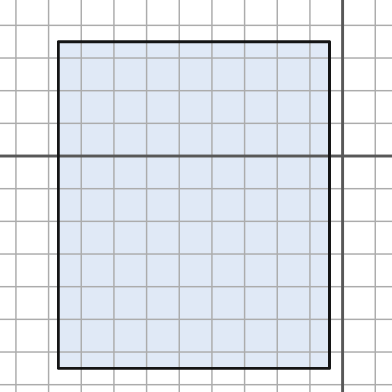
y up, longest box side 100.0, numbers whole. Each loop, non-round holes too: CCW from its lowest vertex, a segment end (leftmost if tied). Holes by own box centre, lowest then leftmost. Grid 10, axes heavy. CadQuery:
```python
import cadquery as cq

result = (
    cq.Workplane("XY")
    .moveTo(-87.0, -65.0)
    .lineTo(-4.0, -65.0)
    .lineTo(-4.0, 35.0)
    .lineTo(-87.0, 35.0)
    .close()
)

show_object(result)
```